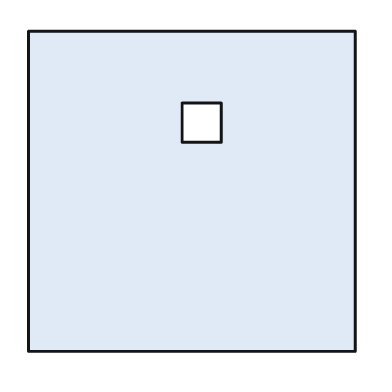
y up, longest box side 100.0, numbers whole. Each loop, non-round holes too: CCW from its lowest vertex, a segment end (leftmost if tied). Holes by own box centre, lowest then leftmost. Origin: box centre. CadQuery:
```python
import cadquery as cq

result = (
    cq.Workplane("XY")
    .moveTo(-50.0, -49.0)
    .lineTo(50.0, -49.0)
    .lineTo(50.0, 49.0)
    .lineTo(-50.0, 49.0)
    .close()
    .moveTo(-3.0, 15.0)
    .lineTo(9.0, 15.0)
    .lineTo(9.0, 27.0)
    .lineTo(-3.0, 27.0)
    .close()
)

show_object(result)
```